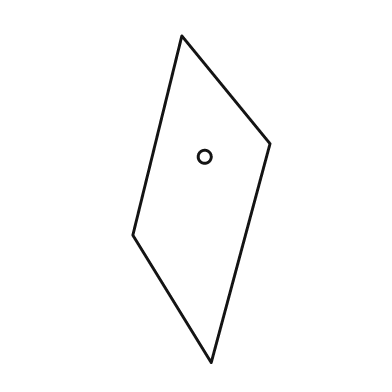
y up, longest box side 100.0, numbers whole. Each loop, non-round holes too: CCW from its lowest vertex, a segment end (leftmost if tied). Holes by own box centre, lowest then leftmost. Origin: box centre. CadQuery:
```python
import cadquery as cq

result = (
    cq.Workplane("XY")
    .moveTo(3.0, -50.0)
    .lineTo(21.0, 17.0)
    .lineTo(-6.0, 50.0)
    .lineTo(-21.0, -11.0)
    .close()
    .moveTo(1.0, 13.0)
    .circle(2.0)
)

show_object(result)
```